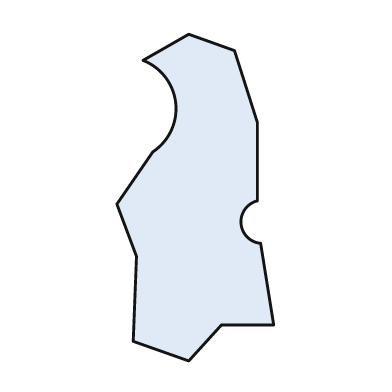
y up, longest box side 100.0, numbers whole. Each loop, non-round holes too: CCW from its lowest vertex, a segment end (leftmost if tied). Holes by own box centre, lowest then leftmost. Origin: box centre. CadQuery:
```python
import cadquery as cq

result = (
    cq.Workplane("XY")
    .moveTo(-2.0, -50.0)
    .lineTo(8.0, -39.0)
    .lineTo(24.0, -39.0)
    .lineTo(20.0, -14.0)
    .threePointArc((14.0, -8.0), (19.0, -1.0))
    .lineTo(19.0, 23.0)
    .lineTo(12.0, 45.0)
    .lineTo(-2.0, 50.0)
    .lineTo(-16.0, 42.0)
    .threePointArc((-6.0, 29.0), (-13.0, 14.0))
    .lineTo(-24.0, -2.0)
    .lineTo(-18.0, -18.0)
    .lineTo(-19.0, -44.0)
    .close()
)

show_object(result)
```